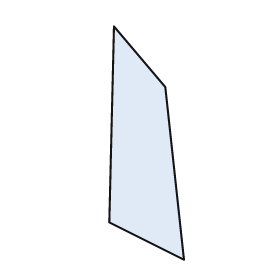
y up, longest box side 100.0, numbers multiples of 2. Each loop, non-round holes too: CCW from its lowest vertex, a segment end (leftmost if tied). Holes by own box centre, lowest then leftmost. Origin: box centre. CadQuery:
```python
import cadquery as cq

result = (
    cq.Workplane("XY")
    .moveTo(16.0, -50.0)
    .lineTo(8.0, 24.0)
    .lineTo(-14.0, 50.0)
    .lineTo(-16.0, -34.0)
    .close()
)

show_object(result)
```